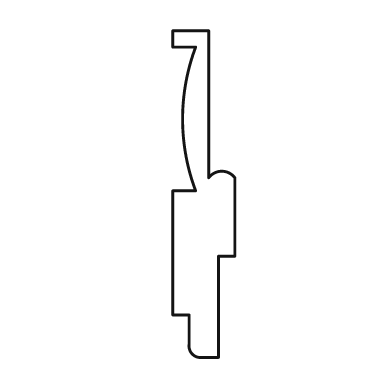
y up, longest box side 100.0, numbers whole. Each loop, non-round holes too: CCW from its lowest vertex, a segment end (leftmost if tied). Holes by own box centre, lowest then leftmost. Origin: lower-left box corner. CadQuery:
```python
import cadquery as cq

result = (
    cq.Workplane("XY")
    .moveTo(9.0, 0.0)
    .lineTo(14.0, 0.0)
    .lineTo(14.0, 31.0)
    .lineTo(19.0, 31.0)
    .lineTo(19.0, 55.0)
    .threePointArc((15.0, 57.0), (11.0, 55.0))
    .lineTo(11.0, 100.0)
    .lineTo(0.0, 100.0)
    .lineTo(0.0, 95.0)
    .lineTo(7.0, 95.0)
    .threePointArc((3.0, 73.0), (7.0, 51.0))
    .lineTo(0.0, 51.0)
    .lineTo(0.0, 13.0)
    .lineTo(5.0, 13.0)
    .lineTo(5.0, 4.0)
    .threePointArc((6.0, 1.0), (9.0, 0.0))
    .close()
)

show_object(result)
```